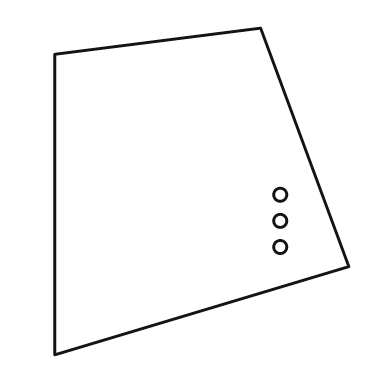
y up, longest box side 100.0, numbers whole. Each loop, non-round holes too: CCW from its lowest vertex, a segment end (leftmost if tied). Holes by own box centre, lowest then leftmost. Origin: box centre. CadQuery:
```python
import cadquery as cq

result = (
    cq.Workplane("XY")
    .moveTo(-45.0, -50.0)
    .lineTo(45.0, -23.0)
    .lineTo(18.0, 50.0)
    .lineTo(-45.0, 42.0)
    .close()
    .moveTo(24.0, -17.0)
    .circle(2.0)
    .moveTo(24.0, -9.0)
    .circle(2.0)
    .moveTo(24.0, -1.0)
    .circle(2.0)
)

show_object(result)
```